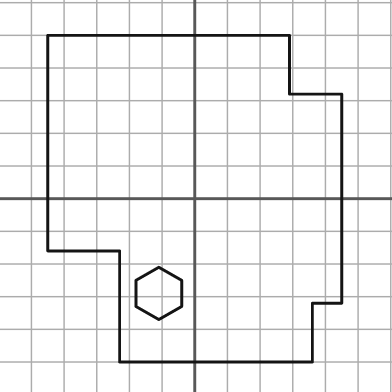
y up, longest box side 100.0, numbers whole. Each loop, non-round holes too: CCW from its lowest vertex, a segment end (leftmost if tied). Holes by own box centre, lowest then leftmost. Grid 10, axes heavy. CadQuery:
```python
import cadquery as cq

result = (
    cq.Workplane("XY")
    .moveTo(-23.0, -50.0)
    .lineTo(36.0, -50.0)
    .lineTo(36.0, -32.0)
    .lineTo(45.0, -32.0)
    .lineTo(45.0, 32.0)
    .lineTo(29.0, 32.0)
    .lineTo(29.0, 50.0)
    .lineTo(-45.0, 50.0)
    .lineTo(-45.0, -16.0)
    .lineTo(-23.0, -16.0)
    .close()
    .moveTo(-11.0, -37.0)
    .lineTo(-4.0, -33.0)
    .lineTo(-4.0, -25.0)
    .lineTo(-11.0, -21.0)
    .lineTo(-18.0, -25.0)
    .lineTo(-18.0, -33.0)
    .close()
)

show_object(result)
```